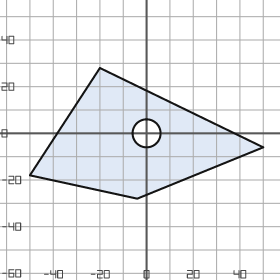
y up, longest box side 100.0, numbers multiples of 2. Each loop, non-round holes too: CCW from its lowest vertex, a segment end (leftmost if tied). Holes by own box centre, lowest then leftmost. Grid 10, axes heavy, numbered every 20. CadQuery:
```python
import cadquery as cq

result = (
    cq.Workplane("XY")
    .moveTo(-4.0, -28.0)
    .lineTo(50.0, -6.0)
    .lineTo(-20.0, 28.0)
    .lineTo(-50.0, -18.0)
    .close()
    .moveTo(0.0, 0.0)
    .circle(6.0)
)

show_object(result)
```